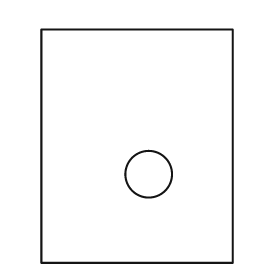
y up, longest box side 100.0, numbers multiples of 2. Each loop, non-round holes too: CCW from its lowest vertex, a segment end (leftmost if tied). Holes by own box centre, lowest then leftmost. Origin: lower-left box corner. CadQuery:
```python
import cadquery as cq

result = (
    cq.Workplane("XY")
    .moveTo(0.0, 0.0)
    .lineTo(82.0, 0.0)
    .lineTo(82.0, 100.0)
    .lineTo(0.0, 100.0)
    .close()
    .moveTo(46.0, 38.0)
    .circle(10.0)
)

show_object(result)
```